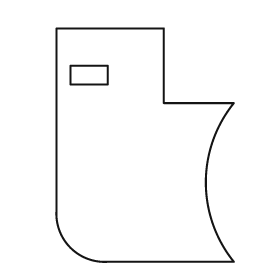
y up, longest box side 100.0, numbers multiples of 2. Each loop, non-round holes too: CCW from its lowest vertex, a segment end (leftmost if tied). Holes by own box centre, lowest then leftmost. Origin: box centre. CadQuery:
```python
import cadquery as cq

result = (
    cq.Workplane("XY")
    .moveTo(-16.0, -50.0)
    .lineTo(38.0, -50.0)
    .threePointArc((26.0, -16.0), (38.0, 18.0))
    .lineTo(8.0, 18.0)
    .lineTo(8.0, 50.0)
    .lineTo(-38.0, 50.0)
    .lineTo(-38.0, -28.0)
    .threePointArc((-32.0, -44.0), (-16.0, -50.0))
    .close()
    .moveTo(-32.0, 26.0)
    .lineTo(-16.0, 26.0)
    .lineTo(-16.0, 34.0)
    .lineTo(-32.0, 34.0)
    .close()
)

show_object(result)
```